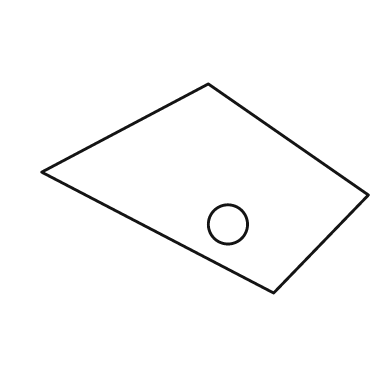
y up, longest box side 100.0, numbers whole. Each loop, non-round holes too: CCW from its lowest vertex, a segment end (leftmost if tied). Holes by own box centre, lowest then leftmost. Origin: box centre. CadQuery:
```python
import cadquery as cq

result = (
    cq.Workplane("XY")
    .moveTo(21.0, -32.0)
    .lineTo(50.0, -2.0)
    .lineTo(1.0, 32.0)
    .lineTo(-50.0, 5.0)
    .close()
    .moveTo(7.0, -11.0)
    .circle(6.0)
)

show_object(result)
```